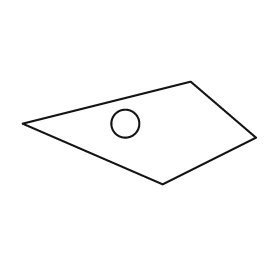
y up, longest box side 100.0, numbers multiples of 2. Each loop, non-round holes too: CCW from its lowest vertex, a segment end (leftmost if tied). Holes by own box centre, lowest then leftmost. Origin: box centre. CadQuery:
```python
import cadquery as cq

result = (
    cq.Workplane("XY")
    .moveTo(10.0, -22.0)
    .lineTo(50.0, -2.0)
    .lineTo(22.0, 22.0)
    .lineTo(-50.0, 4.0)
    .close()
    .moveTo(-6.0, 4.0)
    .circle(6.0)
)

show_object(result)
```